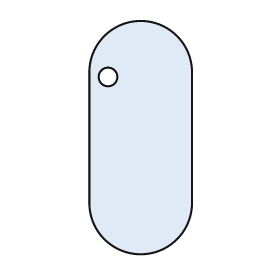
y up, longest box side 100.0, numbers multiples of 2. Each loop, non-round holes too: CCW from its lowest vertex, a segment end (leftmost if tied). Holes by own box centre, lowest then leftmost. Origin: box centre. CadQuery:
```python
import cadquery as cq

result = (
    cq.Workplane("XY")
    .moveTo(-22.0, -28.0)
    .threePointArc((0.0, -50.0), (22.0, -28.0))
    .lineTo(22.0, 28.0)
    .threePointArc((0.0, 50.0), (-22.0, 28.0))
    .close()
    .moveTo(-14.0, 26.0)
    .circle(4.0)
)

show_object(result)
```